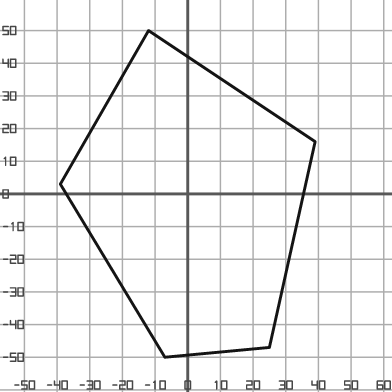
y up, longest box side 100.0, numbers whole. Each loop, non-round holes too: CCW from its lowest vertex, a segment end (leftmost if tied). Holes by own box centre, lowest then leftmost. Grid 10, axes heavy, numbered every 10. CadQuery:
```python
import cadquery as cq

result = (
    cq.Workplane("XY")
    .moveTo(-7.0, -50.0)
    .lineTo(25.0, -47.0)
    .lineTo(39.0, 16.0)
    .lineTo(-12.0, 50.0)
    .lineTo(-39.0, 3.0)
    .close()
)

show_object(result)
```